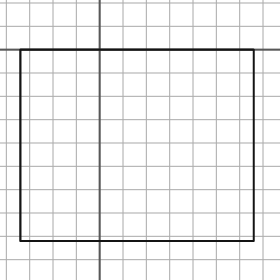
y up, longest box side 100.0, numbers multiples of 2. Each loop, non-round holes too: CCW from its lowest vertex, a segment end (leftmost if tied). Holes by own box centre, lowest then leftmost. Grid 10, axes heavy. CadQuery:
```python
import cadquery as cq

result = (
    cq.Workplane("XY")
    .moveTo(-34.0, -82.0)
    .lineTo(66.0, -82.0)
    .lineTo(66.0, 0.0)
    .lineTo(-34.0, 0.0)
    .close()
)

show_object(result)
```